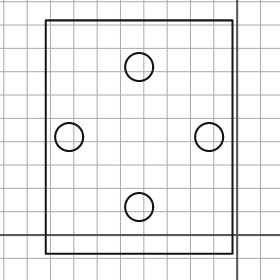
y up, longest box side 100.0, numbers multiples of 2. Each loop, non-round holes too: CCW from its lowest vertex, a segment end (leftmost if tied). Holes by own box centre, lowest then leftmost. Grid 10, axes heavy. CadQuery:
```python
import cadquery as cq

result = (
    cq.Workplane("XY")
    .moveTo(-82.0, -8.0)
    .lineTo(-2.0, -8.0)
    .lineTo(-2.0, 92.0)
    .lineTo(-82.0, 92.0)
    .close()
    .moveTo(-42.0, 12.0)
    .circle(6.0)
    .moveTo(-72.0, 42.0)
    .circle(6.0)
    .moveTo(-12.0, 42.0)
    .circle(6.0)
    .moveTo(-42.0, 72.0)
    .circle(6.0)
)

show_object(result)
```